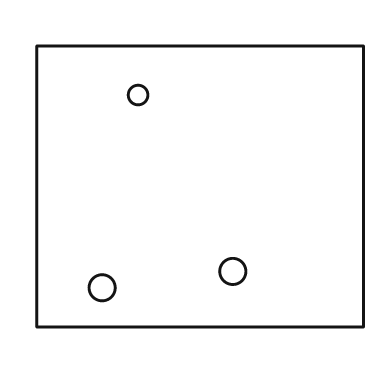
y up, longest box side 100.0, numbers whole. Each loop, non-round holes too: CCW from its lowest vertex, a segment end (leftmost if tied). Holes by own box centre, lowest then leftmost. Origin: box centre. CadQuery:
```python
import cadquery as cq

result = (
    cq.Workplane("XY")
    .moveTo(-50.0, -43.0)
    .lineTo(50.0, -43.0)
    .lineTo(50.0, 43.0)
    .lineTo(-50.0, 43.0)
    .close()
    .moveTo(-30.0, -31.0)
    .circle(4.0)
    .moveTo(10.0, -26.0)
    .circle(4.0)
    .moveTo(-19.0, 28.0)
    .circle(3.0)
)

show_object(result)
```